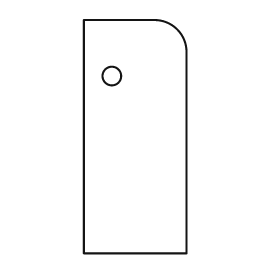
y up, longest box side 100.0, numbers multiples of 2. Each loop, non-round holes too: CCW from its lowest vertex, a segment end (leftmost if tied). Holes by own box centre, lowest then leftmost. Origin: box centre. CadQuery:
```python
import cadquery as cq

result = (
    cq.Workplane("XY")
    .moveTo(-22.0, -50.0)
    .lineTo(22.0, -50.0)
    .lineTo(22.0, 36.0)
    .threePointArc((18.0, 46.0), (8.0, 50.0))
    .lineTo(-22.0, 50.0)
    .close()
    .moveTo(-10.0, 26.0)
    .circle(4.0)
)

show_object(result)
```